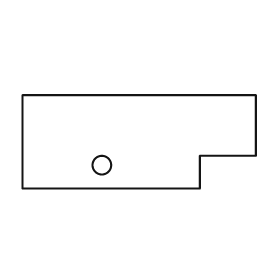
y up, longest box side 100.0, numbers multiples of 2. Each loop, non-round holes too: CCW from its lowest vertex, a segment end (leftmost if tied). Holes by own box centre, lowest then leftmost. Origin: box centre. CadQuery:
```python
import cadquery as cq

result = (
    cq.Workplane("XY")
    .moveTo(-50.0, -20.0)
    .lineTo(26.0, -20.0)
    .lineTo(26.0, -6.0)
    .lineTo(50.0, -6.0)
    .lineTo(50.0, 20.0)
    .lineTo(-50.0, 20.0)
    .close()
    .moveTo(-16.0, -10.0)
    .circle(4.0)
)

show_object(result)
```